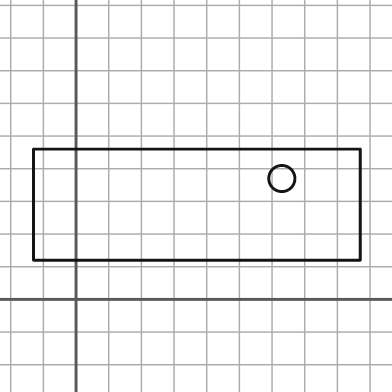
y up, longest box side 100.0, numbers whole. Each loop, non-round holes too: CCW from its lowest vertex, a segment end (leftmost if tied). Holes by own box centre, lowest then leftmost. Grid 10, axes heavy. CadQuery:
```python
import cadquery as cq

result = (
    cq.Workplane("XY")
    .moveTo(-13.0, 12.0)
    .lineTo(87.0, 12.0)
    .lineTo(87.0, 46.0)
    .lineTo(-13.0, 46.0)
    .close()
    .moveTo(63.0, 37.0)
    .circle(4.0)
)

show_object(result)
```